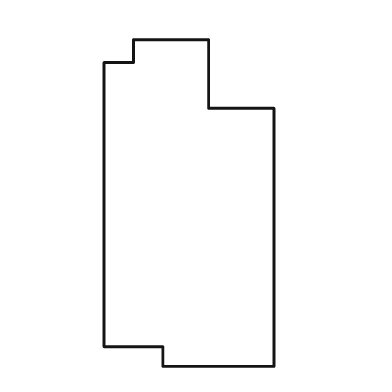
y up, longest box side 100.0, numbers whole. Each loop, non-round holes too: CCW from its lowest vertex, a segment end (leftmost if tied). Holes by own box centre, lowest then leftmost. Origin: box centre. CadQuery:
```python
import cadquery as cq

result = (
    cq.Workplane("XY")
    .moveTo(-8.0, -50.0)
    .lineTo(26.0, -50.0)
    .lineTo(26.0, 29.0)
    .lineTo(6.0, 29.0)
    .lineTo(6.0, 50.0)
    .lineTo(-17.0, 50.0)
    .lineTo(-17.0, 43.0)
    .lineTo(-26.0, 43.0)
    .lineTo(-26.0, -44.0)
    .lineTo(-8.0, -44.0)
    .close()
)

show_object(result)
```